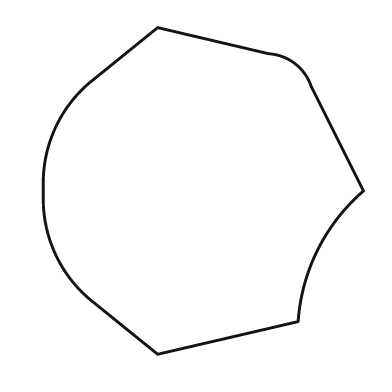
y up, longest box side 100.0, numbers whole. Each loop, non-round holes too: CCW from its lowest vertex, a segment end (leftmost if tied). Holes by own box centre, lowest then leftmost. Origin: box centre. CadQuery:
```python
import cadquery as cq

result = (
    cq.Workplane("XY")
    .moveTo(-14.0, -50.0)
    .lineTo(29.0, -40.0)
    .threePointArc((35.0, -18.0), (49.0, 0.0))
    .lineTo(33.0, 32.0)
    .threePointArc((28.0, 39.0), (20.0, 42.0))
    .lineTo(-14.0, 50.0)
    .lineTo(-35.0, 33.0)
    .threePointArc((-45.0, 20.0), (-49.0, 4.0))
    .lineTo(-49.0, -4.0)
    .threePointArc((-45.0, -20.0), (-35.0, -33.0))
    .close()
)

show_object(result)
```